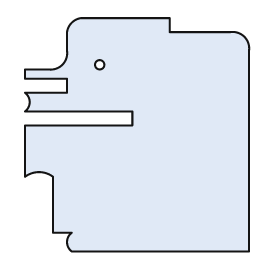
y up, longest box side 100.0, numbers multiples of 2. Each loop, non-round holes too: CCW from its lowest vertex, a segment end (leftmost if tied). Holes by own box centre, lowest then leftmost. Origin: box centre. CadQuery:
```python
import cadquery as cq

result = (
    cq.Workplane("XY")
    .moveTo(-28.0, -50.0)
    .lineTo(48.0, -50.0)
    .lineTo(48.0, 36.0)
    .threePointArc((46.0, 42.0), (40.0, 44.0))
    .lineTo(14.0, 44.0)
    .lineTo(14.0, 50.0)
    .lineTo(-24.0, 50.0)
    .threePointArc((-28.0, 48.0), (-30.0, 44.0))
    .lineTo(-30.0, 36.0)
    .threePointArc((-32.0, 30.0), (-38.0, 28.0))
    .lineTo(-48.0, 28.0)
    .lineTo(-48.0, 24.0)
    .lineTo(-30.0, 24.0)
    .lineTo(-30.0, 18.0)
    .lineTo(-48.0, 18.0)
    .threePointArc((-46.0, 14.0), (-48.0, 10.0))
    .lineTo(-2.0, 10.0)
    .lineTo(-2.0, 4.0)
    .lineTo(-48.0, 4.0)
    .lineTo(-48.0, -18.0)
    .threePointArc((-42.0, -16.0), (-36.0, -18.0))
    .lineTo(-36.0, -42.0)
    .lineTo(-28.0, -42.0)
    .threePointArc((-30.0, -46.0), (-28.0, -50.0))
    .close()
    .moveTo(-16.0, 30.0)
    .circle(2.0)
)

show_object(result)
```